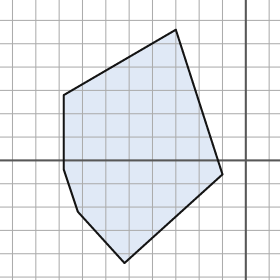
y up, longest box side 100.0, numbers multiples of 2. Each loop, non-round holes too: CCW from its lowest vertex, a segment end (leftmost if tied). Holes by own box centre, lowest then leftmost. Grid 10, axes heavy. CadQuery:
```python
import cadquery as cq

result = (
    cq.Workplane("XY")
    .moveTo(-52.0, -44.0)
    .lineTo(-10.0, -6.0)
    .lineTo(-30.0, 56.0)
    .lineTo(-78.0, 28.0)
    .lineTo(-78.0, -4.0)
    .lineTo(-72.0, -22.0)
    .close()
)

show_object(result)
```